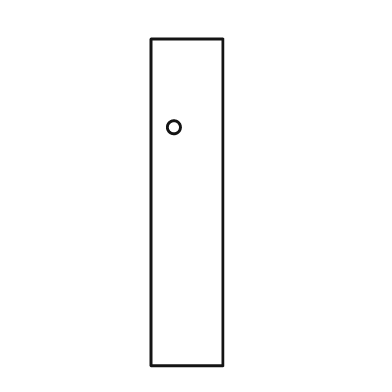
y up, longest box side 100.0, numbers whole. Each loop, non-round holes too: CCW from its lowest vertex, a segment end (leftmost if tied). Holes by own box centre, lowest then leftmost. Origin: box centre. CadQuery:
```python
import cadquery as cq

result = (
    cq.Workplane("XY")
    .moveTo(-11.0, -50.0)
    .lineTo(11.0, -50.0)
    .lineTo(11.0, 50.0)
    .lineTo(-11.0, 50.0)
    .close()
    .moveTo(-4.0, 23.0)
    .circle(2.0)
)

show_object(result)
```